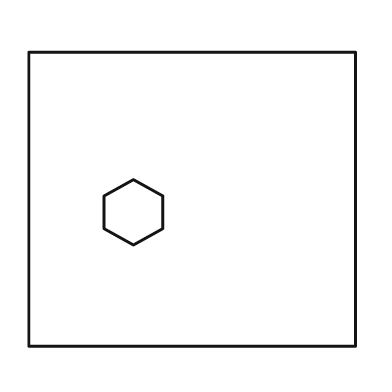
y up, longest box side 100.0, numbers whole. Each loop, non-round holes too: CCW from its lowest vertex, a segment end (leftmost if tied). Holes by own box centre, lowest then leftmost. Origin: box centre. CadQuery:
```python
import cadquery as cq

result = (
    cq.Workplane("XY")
    .moveTo(-50.0, -45.0)
    .lineTo(50.0, -45.0)
    .lineTo(50.0, 45.0)
    .lineTo(-50.0, 45.0)
    .close()
    .moveTo(-18.0, -14.0)
    .lineTo(-9.0, -9.0)
    .lineTo(-9.0, 1.0)
    .lineTo(-18.0, 6.0)
    .lineTo(-27.0, 1.0)
    .lineTo(-27.0, -9.0)
    .close()
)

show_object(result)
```